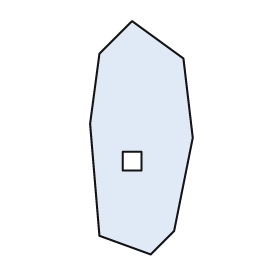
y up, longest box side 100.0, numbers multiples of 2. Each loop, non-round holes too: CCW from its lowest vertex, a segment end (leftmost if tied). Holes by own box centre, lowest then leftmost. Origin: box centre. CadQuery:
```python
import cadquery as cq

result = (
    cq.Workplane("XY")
    .moveTo(4.0, -50.0)
    .lineTo(14.0, -40.0)
    .lineTo(22.0, 0.0)
    .lineTo(18.0, 34.0)
    .lineTo(-4.0, 50.0)
    .lineTo(-18.0, 36.0)
    .lineTo(-22.0, 6.0)
    .lineTo(-18.0, -42.0)
    .close()
    .moveTo(-8.0, -14.0)
    .lineTo(0.0, -14.0)
    .lineTo(0.0, -6.0)
    .lineTo(-8.0, -6.0)
    .close()
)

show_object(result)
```